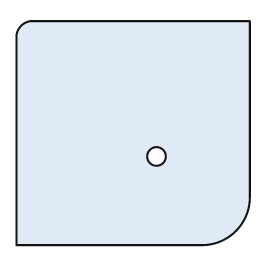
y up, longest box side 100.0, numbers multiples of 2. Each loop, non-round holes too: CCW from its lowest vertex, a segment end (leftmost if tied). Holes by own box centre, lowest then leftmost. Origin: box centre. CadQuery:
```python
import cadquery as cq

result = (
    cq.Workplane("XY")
    .moveTo(-50.0, -48.0)
    .lineTo(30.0, -48.0)
    .threePointArc((44.0, -42.0), (50.0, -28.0))
    .lineTo(50.0, 48.0)
    .lineTo(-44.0, 48.0)
    .threePointArc((-48.0, 46.0), (-50.0, 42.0))
    .close()
    .moveTo(10.0, -10.0)
    .circle(4.0)
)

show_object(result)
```